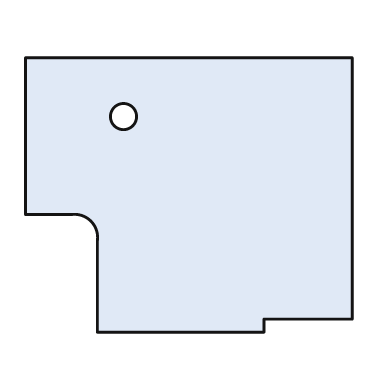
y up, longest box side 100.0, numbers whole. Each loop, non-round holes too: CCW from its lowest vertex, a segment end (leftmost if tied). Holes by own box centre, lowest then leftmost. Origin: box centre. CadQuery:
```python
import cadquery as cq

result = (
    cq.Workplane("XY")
    .moveTo(-28.0, -42.0)
    .lineTo(23.0, -42.0)
    .lineTo(23.0, -38.0)
    .lineTo(50.0, -38.0)
    .lineTo(50.0, 42.0)
    .lineTo(-50.0, 42.0)
    .lineTo(-50.0, -6.0)
    .lineTo(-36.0, -6.0)
    .threePointArc((-30.0, -8.0), (-28.0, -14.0))
    .close()
    .moveTo(-20.0, 24.0)
    .circle(4.0)
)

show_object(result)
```